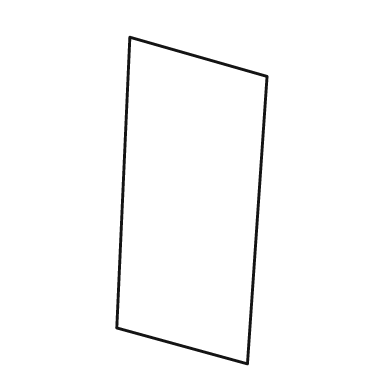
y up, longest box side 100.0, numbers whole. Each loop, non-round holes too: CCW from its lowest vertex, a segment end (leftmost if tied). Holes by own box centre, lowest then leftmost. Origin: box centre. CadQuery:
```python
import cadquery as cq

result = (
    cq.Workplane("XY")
    .moveTo(17.0, -50.0)
    .lineTo(23.0, 38.0)
    .lineTo(-19.0, 50.0)
    .lineTo(-23.0, -39.0)
    .close()
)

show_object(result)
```